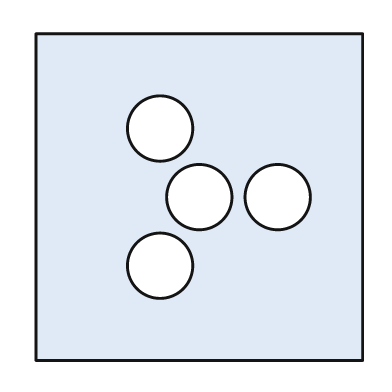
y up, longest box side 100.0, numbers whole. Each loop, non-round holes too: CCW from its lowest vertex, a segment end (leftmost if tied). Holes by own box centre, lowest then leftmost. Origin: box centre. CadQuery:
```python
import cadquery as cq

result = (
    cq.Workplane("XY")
    .moveTo(-50.0, -50.0)
    .lineTo(50.0, -50.0)
    .lineTo(50.0, 50.0)
    .lineTo(-50.0, 50.0)
    .close()
    .moveTo(-12.0, -21.0)
    .circle(10.0)
    .moveTo(0.0, 0.0)
    .circle(10.0)
    .moveTo(24.0, 0.0)
    .circle(10.0)
    .moveTo(-12.0, 21.0)
    .circle(10.0)
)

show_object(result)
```